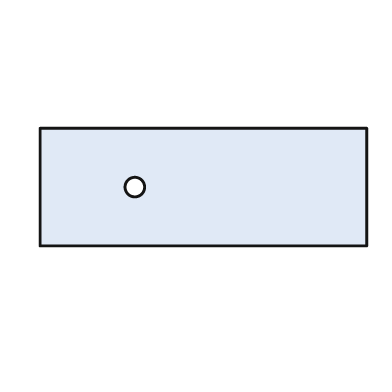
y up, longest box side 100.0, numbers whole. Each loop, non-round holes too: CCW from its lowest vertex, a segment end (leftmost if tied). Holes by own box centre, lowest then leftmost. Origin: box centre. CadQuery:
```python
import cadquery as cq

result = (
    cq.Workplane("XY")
    .moveTo(-50.0, -18.0)
    .lineTo(50.0, -18.0)
    .lineTo(50.0, 18.0)
    .lineTo(-50.0, 18.0)
    .close()
    .moveTo(-21.0, 0.0)
    .circle(3.0)
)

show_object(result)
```